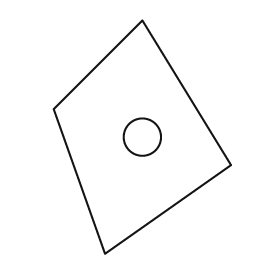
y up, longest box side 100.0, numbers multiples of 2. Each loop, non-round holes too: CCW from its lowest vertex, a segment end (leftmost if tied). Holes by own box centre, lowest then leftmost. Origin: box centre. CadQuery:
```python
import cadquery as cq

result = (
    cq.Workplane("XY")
    .moveTo(-16.0, -50.0)
    .lineTo(38.0, -12.0)
    .lineTo(0.0, 50.0)
    .lineTo(-38.0, 12.0)
    .close()
    .moveTo(0.0, 0.0)
    .circle(8.0)
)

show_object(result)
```